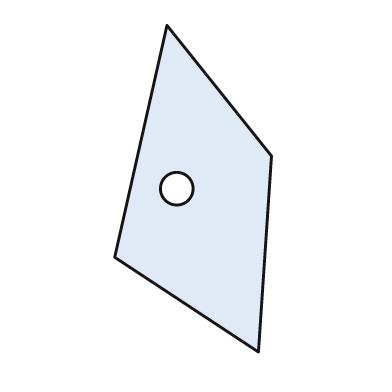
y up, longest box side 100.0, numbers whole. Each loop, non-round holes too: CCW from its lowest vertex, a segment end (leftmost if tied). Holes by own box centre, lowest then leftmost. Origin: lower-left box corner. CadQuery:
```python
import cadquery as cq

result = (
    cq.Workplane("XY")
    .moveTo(44.0, 0.0)
    .lineTo(48.0, 60.0)
    .lineTo(16.0, 100.0)
    .lineTo(0.0, 29.0)
    .close()
    .moveTo(19.0, 50.0)
    .circle(5.0)
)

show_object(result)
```